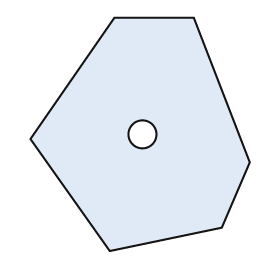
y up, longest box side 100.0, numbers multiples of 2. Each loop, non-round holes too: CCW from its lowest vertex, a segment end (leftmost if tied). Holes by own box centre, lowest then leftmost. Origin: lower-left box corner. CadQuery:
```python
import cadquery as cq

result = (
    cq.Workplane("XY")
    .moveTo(34.0, 0.0)
    .lineTo(82.0, 10.0)
    .lineTo(94.0, 38.0)
    .lineTo(70.0, 100.0)
    .lineTo(36.0, 100.0)
    .lineTo(0.0, 48.0)
    .close()
    .moveTo(48.0, 50.0)
    .circle(6.0)
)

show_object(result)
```